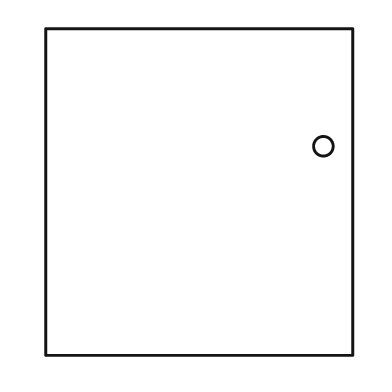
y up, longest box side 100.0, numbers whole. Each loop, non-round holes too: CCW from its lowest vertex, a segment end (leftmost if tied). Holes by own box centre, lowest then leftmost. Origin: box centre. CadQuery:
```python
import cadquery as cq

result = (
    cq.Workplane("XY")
    .moveTo(-47.0, -50.0)
    .lineTo(47.0, -50.0)
    .lineTo(47.0, 50.0)
    .lineTo(-47.0, 50.0)
    .close()
    .moveTo(38.0, 14.0)
    .circle(3.0)
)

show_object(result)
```